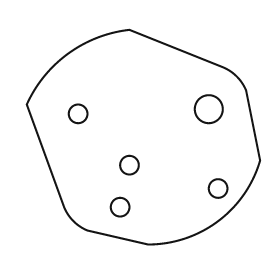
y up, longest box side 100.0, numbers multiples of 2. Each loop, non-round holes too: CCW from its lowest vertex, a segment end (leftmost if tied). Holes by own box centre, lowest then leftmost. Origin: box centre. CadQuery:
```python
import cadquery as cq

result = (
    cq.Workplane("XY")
    .moveTo(2.0, -46.0)
    .threePointArc((32.0, -36.0), (50.0, -10.0))
    .lineTo(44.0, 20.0)
    .threePointArc((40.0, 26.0), (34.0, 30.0))
    .lineTo(-6.0, 46.0)
    .threePointArc((-32.0, 36.0), (-50.0, 14.0))
    .lineTo(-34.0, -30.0)
    .threePointArc((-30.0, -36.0), (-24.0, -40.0))
    .close()
    .moveTo(-10.0, -30.0)
    .circle(4.0)
    .moveTo(32.0, -22.0)
    .circle(4.0)
    .moveTo(-6.0, -12.0)
    .circle(4.0)
    .moveTo(-28.0, 10.0)
    .circle(4.0)
    .moveTo(28.0, 12.0)
    .circle(6.0)
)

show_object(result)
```